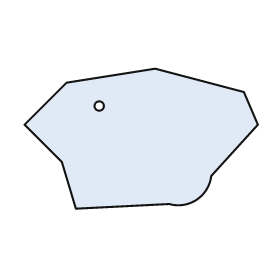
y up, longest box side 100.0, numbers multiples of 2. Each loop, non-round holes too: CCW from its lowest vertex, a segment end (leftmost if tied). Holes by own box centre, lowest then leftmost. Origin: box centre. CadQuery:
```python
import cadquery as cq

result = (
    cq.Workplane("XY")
    .moveTo(-28.0, -30.0)
    .lineTo(12.0, -28.0)
    .threePointArc((24.0, -26.0), (30.0, -16.0))
    .lineTo(50.0, 6.0)
    .lineTo(44.0, 20.0)
    .lineTo(6.0, 30.0)
    .lineTo(-32.0, 24.0)
    .lineTo(-50.0, 6.0)
    .lineTo(-34.0, -10.0)
    .close()
    .moveTo(-18.0, 14.0)
    .circle(2.0)
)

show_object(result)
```